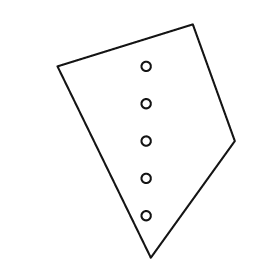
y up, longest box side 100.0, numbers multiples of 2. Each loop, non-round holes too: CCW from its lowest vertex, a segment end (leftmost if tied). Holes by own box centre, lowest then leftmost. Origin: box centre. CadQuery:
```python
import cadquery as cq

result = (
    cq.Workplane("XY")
    .moveTo(2.0, -50.0)
    .lineTo(38.0, 0.0)
    .lineTo(20.0, 50.0)
    .lineTo(-38.0, 32.0)
    .close()
    .moveTo(0.0, -32.0)
    .circle(2.0)
    .moveTo(0.0, -16.0)
    .circle(2.0)
    .moveTo(0.0, 0.0)
    .circle(2.0)
    .moveTo(0.0, 16.0)
    .circle(2.0)
    .moveTo(0.0, 32.0)
    .circle(2.0)
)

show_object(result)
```